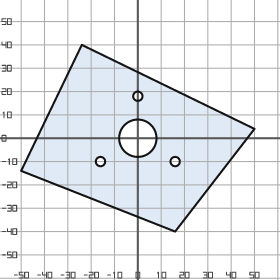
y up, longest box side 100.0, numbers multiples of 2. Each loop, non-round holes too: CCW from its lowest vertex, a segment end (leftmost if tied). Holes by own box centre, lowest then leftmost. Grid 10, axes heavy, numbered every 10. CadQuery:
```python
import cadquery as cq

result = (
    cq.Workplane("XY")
    .moveTo(16.0, -40.0)
    .lineTo(50.0, 4.0)
    .lineTo(-24.0, 40.0)
    .lineTo(-50.0, -14.0)
    .close()
    .moveTo(-16.0, -10.0)
    .circle(2.0)
    .moveTo(16.0, -10.0)
    .circle(2.0)
    .moveTo(0.0, 0.0)
    .circle(8.0)
    .moveTo(0.0, 18.0)
    .circle(2.0)
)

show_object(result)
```